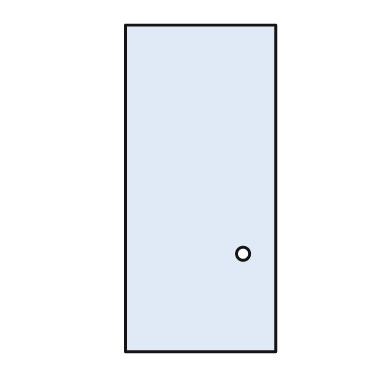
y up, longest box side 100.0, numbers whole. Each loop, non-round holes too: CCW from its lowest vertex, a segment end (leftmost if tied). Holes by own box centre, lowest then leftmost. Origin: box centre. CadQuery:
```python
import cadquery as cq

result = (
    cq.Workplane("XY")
    .moveTo(-23.0, -50.0)
    .lineTo(23.0, -50.0)
    .lineTo(23.0, 50.0)
    .lineTo(-23.0, 50.0)
    .close()
    .moveTo(13.0, -20.0)
    .circle(2.0)
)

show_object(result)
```